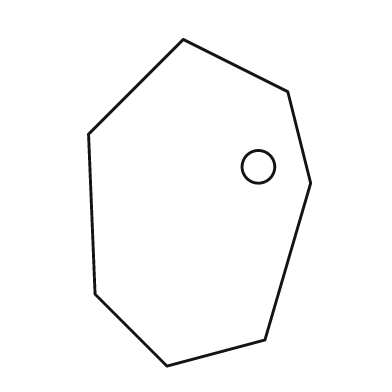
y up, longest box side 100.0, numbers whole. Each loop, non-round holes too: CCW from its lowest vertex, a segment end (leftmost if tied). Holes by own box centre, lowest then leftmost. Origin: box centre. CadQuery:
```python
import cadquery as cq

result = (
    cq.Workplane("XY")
    .moveTo(-10.0, -50.0)
    .lineTo(20.0, -42.0)
    .lineTo(34.0, 6.0)
    .lineTo(27.0, 34.0)
    .lineTo(-5.0, 50.0)
    .lineTo(-34.0, 21.0)
    .lineTo(-32.0, -28.0)
    .close()
    .moveTo(18.0, 11.0)
    .circle(5.0)
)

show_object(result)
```